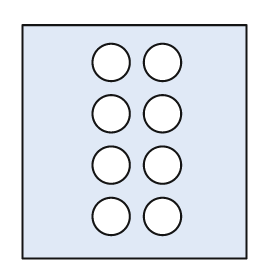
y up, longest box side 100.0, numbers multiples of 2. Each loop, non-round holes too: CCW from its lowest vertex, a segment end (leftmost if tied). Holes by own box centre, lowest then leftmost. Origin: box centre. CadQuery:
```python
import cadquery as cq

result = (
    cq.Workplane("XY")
    .moveTo(-48.0, -50.0)
    .lineTo(48.0, -50.0)
    .lineTo(48.0, 50.0)
    .lineTo(-48.0, 50.0)
    .close()
    .moveTo(-10.0, -32.0)
    .circle(8.0)
    .moveTo(12.0, -32.0)
    .circle(8.0)
    .moveTo(-10.0, -10.0)
    .circle(8.0)
    .moveTo(12.0, -10.0)
    .circle(8.0)
    .moveTo(-10.0, 12.0)
    .circle(8.0)
    .moveTo(12.0, 12.0)
    .circle(8.0)
    .moveTo(-10.0, 34.0)
    .circle(8.0)
    .moveTo(12.0, 34.0)
    .circle(8.0)
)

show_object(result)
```